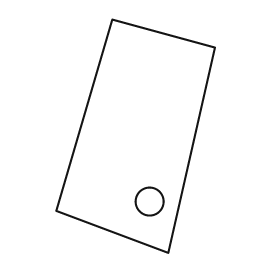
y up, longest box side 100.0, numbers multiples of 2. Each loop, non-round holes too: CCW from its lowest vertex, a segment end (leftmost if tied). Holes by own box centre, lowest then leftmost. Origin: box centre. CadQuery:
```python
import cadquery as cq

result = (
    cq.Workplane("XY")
    .moveTo(14.0, -50.0)
    .lineTo(34.0, 38.0)
    .lineTo(-10.0, 50.0)
    .lineTo(-34.0, -32.0)
    .close()
    .moveTo(6.0, -28.0)
    .circle(6.0)
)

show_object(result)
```